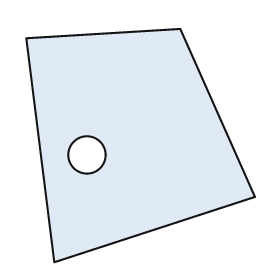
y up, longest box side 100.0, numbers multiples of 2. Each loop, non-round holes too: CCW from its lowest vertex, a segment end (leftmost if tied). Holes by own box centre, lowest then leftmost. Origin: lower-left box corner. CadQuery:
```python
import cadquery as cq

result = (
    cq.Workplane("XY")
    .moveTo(12.0, 0.0)
    .lineTo(98.0, 28.0)
    .lineTo(66.0, 100.0)
    .lineTo(0.0, 96.0)
    .close()
    .moveTo(26.0, 46.0)
    .circle(8.0)
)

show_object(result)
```